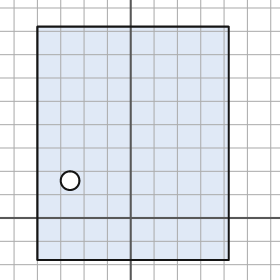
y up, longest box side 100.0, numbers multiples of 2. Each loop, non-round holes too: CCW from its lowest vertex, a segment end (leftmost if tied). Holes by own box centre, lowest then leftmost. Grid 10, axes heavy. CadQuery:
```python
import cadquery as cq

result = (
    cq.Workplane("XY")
    .moveTo(-40.0, -18.0)
    .lineTo(42.0, -18.0)
    .lineTo(42.0, 82.0)
    .lineTo(-40.0, 82.0)
    .close()
    .moveTo(-26.0, 16.0)
    .circle(4.0)
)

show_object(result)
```